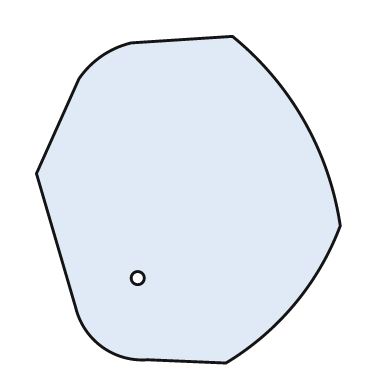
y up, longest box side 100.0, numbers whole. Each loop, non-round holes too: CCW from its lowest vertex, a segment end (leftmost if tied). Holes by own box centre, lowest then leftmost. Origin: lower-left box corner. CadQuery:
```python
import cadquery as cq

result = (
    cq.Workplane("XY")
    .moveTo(58.0, 0.0)
    .threePointArc((79.0, 18.0), (93.0, 42.0))
    .threePointArc((82.0, 74.0), (60.0, 100.0))
    .lineTo(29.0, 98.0)
    .threePointArc((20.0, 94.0), (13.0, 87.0))
    .lineTo(0.0, 58.0)
    .lineTo(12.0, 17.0)
    .threePointArc((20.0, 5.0), (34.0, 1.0))
    .close()
    .moveTo(31.0, 26.0)
    .circle(2.0)
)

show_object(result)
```